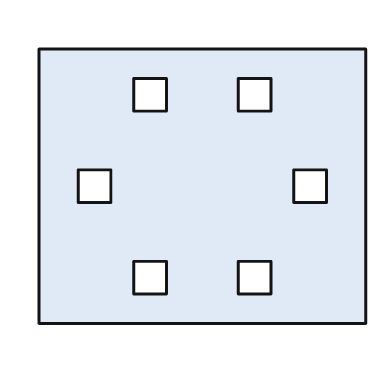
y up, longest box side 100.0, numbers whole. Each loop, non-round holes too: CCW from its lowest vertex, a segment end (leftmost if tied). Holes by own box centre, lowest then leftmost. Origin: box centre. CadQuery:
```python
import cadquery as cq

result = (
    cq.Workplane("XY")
    .moveTo(-50.0, -42.0)
    .lineTo(50.0, -42.0)
    .lineTo(50.0, 42.0)
    .lineTo(-50.0, 42.0)
    .close()
    .moveTo(-21.0, -33.0)
    .lineTo(-11.0, -33.0)
    .lineTo(-11.0, -23.0)
    .lineTo(-21.0, -23.0)
    .close()
    .moveTo(11.0, -33.0)
    .lineTo(21.0, -33.0)
    .lineTo(21.0, -23.0)
    .lineTo(11.0, -23.0)
    .close()
    .moveTo(-38.0, -5.0)
    .lineTo(-28.0, -5.0)
    .lineTo(-28.0, 5.0)
    .lineTo(-38.0, 5.0)
    .close()
    .moveTo(28.0, -5.0)
    .lineTo(38.0, -5.0)
    .lineTo(38.0, 5.0)
    .lineTo(28.0, 5.0)
    .close()
    .moveTo(-21.0, 23.0)
    .lineTo(-11.0, 23.0)
    .lineTo(-11.0, 33.0)
    .lineTo(-21.0, 33.0)
    .close()
    .moveTo(11.0, 23.0)
    .lineTo(21.0, 23.0)
    .lineTo(21.0, 33.0)
    .lineTo(11.0, 33.0)
    .close()
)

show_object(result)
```